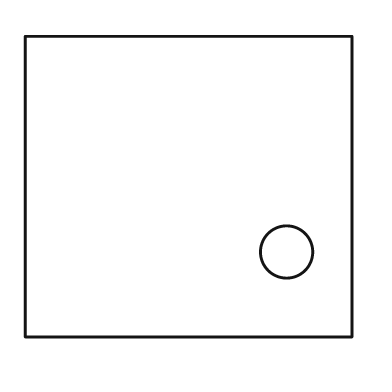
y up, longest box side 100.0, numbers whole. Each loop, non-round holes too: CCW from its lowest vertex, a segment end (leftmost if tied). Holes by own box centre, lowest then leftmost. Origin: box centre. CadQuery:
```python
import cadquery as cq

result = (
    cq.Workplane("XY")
    .moveTo(-50.0, -46.0)
    .lineTo(50.0, -46.0)
    .lineTo(50.0, 46.0)
    .lineTo(-50.0, 46.0)
    .close()
    .moveTo(30.0, -20.0)
    .circle(8.0)
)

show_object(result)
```